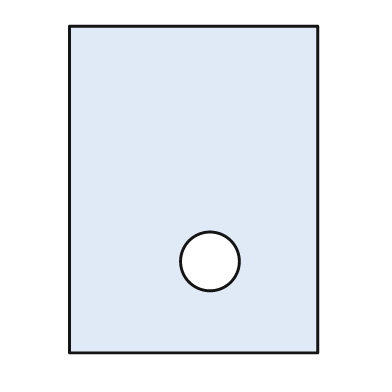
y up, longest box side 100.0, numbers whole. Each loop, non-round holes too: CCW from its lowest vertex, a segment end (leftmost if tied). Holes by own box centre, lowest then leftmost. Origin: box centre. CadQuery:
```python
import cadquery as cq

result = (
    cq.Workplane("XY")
    .moveTo(-38.0, -50.0)
    .lineTo(38.0, -50.0)
    .lineTo(38.0, 50.0)
    .lineTo(-38.0, 50.0)
    .close()
    .moveTo(5.0, -22.0)
    .circle(9.0)
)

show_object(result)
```